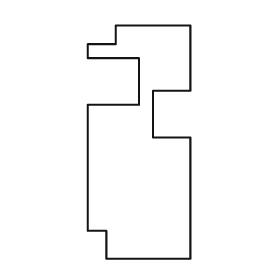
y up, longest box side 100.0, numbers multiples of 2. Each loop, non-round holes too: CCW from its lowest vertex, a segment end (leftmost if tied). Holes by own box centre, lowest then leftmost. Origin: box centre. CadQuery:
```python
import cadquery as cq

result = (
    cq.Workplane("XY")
    .moveTo(-14.0, -50.0)
    .lineTo(22.0, -50.0)
    .lineTo(22.0, 2.0)
    .lineTo(6.0, 2.0)
    .lineTo(6.0, 22.0)
    .lineTo(22.0, 22.0)
    .lineTo(22.0, 50.0)
    .lineTo(-10.0, 50.0)
    .lineTo(-10.0, 42.0)
    .lineTo(-22.0, 42.0)
    .lineTo(-22.0, 36.0)
    .lineTo(0.0, 36.0)
    .lineTo(0.0, 16.0)
    .lineTo(-22.0, 16.0)
    .lineTo(-22.0, -38.0)
    .lineTo(-14.0, -38.0)
    .close()
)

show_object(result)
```